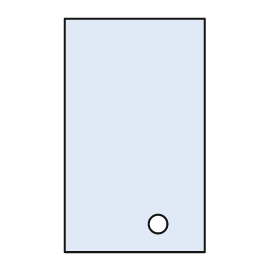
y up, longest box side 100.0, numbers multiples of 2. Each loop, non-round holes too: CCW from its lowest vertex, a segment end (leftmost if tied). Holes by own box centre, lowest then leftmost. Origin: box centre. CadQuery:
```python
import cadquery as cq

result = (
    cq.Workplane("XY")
    .moveTo(-30.0, -50.0)
    .lineTo(30.0, -50.0)
    .lineTo(30.0, 50.0)
    .lineTo(-30.0, 50.0)
    .close()
    .moveTo(10.0, -38.0)
    .circle(4.0)
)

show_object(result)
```